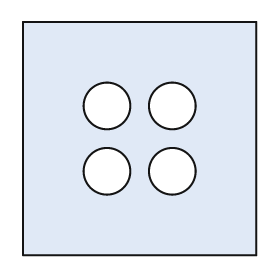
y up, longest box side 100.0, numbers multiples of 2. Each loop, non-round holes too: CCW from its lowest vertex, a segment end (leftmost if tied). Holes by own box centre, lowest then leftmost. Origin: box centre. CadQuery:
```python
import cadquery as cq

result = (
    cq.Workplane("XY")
    .moveTo(-50.0, -50.0)
    .lineTo(50.0, -50.0)
    .lineTo(50.0, 50.0)
    .lineTo(-50.0, 50.0)
    .close()
    .moveTo(-14.0, -14.0)
    .circle(10.0)
    .moveTo(14.0, -14.0)
    .circle(10.0)
    .moveTo(-14.0, 14.0)
    .circle(10.0)
    .moveTo(14.0, 14.0)
    .circle(10.0)
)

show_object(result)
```